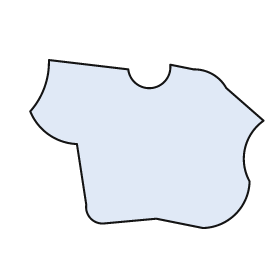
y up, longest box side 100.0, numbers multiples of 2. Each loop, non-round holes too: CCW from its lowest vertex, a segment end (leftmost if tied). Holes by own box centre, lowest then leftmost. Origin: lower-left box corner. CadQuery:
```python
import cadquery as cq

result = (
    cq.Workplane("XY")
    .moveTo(74.0, 0.0)
    .threePointArc((88.0, 6.0), (94.0, 20.0))
    .threePointArc((92.0, 34.0), (100.0, 46.0))
    .lineTo(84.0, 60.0)
    .threePointArc((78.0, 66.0), (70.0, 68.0))
    .lineTo(60.0, 70.0)
    .threePointArc((52.0, 60.0), (42.0, 68.0))
    .lineTo(8.0, 72.0)
    .threePointArc((6.0, 60.0), (0.0, 50.0))
    .threePointArc((8.0, 40.0), (20.0, 36.0))
    .lineTo(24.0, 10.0)
    .threePointArc((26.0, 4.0), (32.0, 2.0))
    .lineTo(54.0, 4.0)
    .close()
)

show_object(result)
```